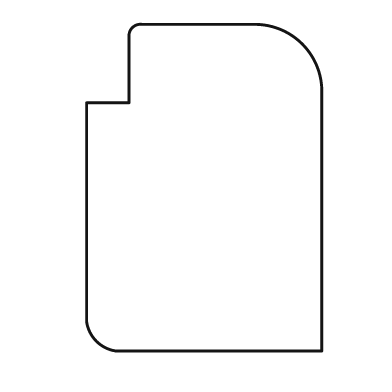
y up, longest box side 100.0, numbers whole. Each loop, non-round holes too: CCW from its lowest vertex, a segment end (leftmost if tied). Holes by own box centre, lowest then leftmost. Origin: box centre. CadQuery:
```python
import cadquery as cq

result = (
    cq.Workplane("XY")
    .moveTo(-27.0, -50.0)
    .lineTo(36.0, -50.0)
    .lineTo(36.0, 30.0)
    .threePointArc((30.0, 44.0), (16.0, 50.0))
    .lineTo(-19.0, 50.0)
    .threePointArc((-22.0, 49.0), (-23.0, 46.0))
    .lineTo(-23.0, 26.0)
    .lineTo(-36.0, 26.0)
    .lineTo(-36.0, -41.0)
    .threePointArc((-33.0, -47.0), (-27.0, -50.0))
    .close()
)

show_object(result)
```